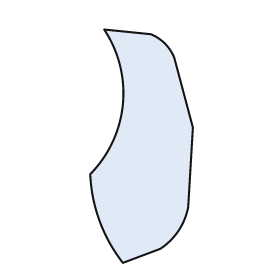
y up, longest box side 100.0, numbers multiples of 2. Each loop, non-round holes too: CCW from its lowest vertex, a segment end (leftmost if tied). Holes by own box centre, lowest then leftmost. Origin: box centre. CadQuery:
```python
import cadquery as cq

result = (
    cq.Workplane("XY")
    .moveTo(-8.0, -50.0)
    .lineTo(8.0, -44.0)
    .threePointArc((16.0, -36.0), (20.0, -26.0))
    .lineTo(22.0, 8.0)
    .lineTo(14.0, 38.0)
    .threePointArc((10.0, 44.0), (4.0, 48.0))
    .lineTo(-16.0, 50.0)
    .threePointArc((-8.0, 18.0), (-22.0, -12.0))
    .threePointArc((-18.0, -32.0), (-8.0, -50.0))
    .close()
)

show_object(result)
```